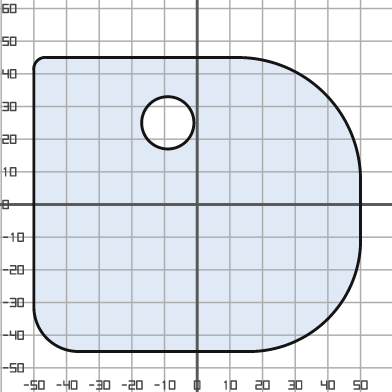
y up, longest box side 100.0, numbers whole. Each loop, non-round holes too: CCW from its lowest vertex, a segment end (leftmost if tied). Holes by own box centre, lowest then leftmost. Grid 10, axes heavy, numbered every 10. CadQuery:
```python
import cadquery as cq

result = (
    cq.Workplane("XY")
    .moveTo(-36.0, -45.0)
    .lineTo(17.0, -45.0)
    .threePointArc((40.0, -35.0), (50.0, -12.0))
    .lineTo(50.0, 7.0)
    .threePointArc((39.0, 34.0), (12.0, 45.0))
    .lineTo(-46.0, 45.0)
    .threePointArc((-49.0, 44.0), (-50.0, 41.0))
    .lineTo(-50.0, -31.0)
    .threePointArc((-46.0, -41.0), (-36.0, -45.0))
    .close()
    .moveTo(-9.0, 25.0)
    .circle(8.0)
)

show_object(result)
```